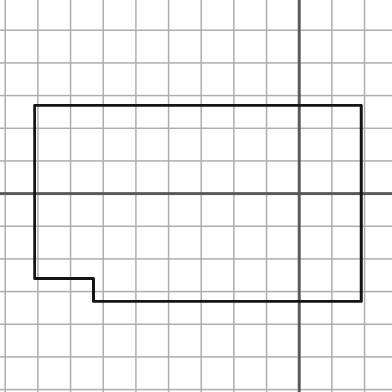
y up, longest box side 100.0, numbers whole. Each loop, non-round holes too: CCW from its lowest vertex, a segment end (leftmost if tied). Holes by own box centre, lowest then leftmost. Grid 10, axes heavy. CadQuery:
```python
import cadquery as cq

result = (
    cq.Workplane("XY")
    .moveTo(-63.0, -33.0)
    .lineTo(19.0, -33.0)
    .lineTo(19.0, 27.0)
    .lineTo(-81.0, 27.0)
    .lineTo(-81.0, -26.0)
    .lineTo(-63.0, -26.0)
    .close()
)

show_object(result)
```